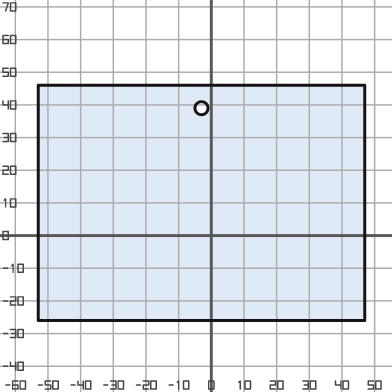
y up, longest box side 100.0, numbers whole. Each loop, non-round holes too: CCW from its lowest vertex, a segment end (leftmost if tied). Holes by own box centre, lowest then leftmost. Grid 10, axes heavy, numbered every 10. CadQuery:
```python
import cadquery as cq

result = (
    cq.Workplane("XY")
    .moveTo(-53.0, -26.0)
    .lineTo(47.0, -26.0)
    .lineTo(47.0, 46.0)
    .lineTo(-53.0, 46.0)
    .close()
    .moveTo(-3.0, 39.0)
    .circle(2.0)
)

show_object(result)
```